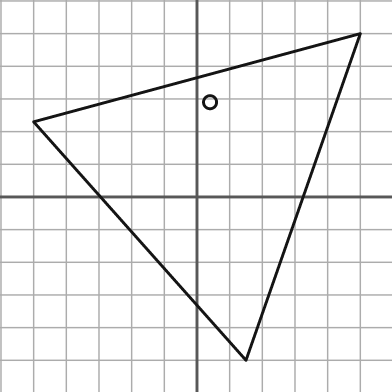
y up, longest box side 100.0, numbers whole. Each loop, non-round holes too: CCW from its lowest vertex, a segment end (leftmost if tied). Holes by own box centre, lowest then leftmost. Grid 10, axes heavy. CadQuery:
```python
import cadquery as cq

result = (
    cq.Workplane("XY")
    .moveTo(15.0, -50.0)
    .lineTo(50.0, 50.0)
    .lineTo(-50.0, 23.0)
    .close()
    .moveTo(4.0, 29.0)
    .circle(2.0)
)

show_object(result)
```